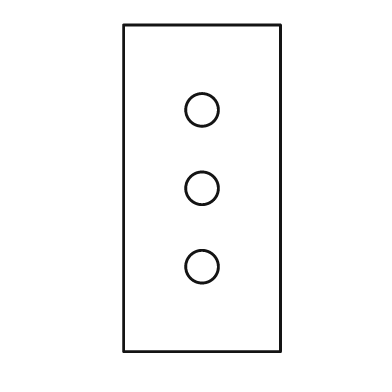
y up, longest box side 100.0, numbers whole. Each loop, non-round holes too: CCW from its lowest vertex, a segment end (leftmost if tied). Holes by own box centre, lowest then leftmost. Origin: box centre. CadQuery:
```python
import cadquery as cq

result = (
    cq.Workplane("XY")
    .moveTo(-24.0, -50.0)
    .lineTo(24.0, -50.0)
    .lineTo(24.0, 50.0)
    .lineTo(-24.0, 50.0)
    .close()
    .moveTo(0.0, -24.0)
    .circle(5.0)
    .moveTo(0.0, 0.0)
    .circle(5.0)
    .moveTo(0.0, 24.0)
    .circle(5.0)
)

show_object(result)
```